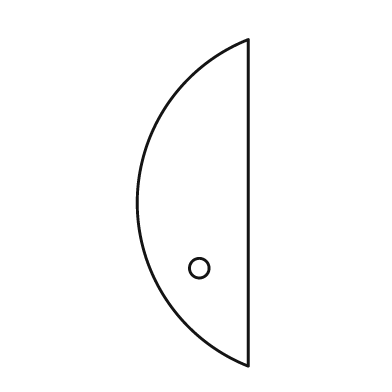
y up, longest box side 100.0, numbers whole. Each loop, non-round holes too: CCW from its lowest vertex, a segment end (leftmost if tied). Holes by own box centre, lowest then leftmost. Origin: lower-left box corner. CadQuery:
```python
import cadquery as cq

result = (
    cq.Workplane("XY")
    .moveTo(34.0, 0.0)
    .lineTo(34.0, 100.0)
    .threePointArc((0.0, 50.0), (34.0, 0.0))
    .close()
    .moveTo(19.0, 30.0)
    .circle(3.0)
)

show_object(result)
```